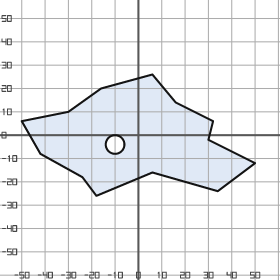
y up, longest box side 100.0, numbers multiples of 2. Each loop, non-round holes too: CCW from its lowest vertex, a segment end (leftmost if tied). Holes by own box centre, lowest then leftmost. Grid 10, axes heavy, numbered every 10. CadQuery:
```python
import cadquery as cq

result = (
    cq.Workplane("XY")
    .moveTo(-18.0, -26.0)
    .lineTo(6.0, -16.0)
    .lineTo(34.0, -24.0)
    .lineTo(50.0, -12.0)
    .lineTo(30.0, -2.0)
    .lineTo(32.0, 6.0)
    .lineTo(16.0, 14.0)
    .lineTo(6.0, 26.0)
    .lineTo(-16.0, 20.0)
    .lineTo(-30.0, 10.0)
    .lineTo(-50.0, 6.0)
    .lineTo(-42.0, -8.0)
    .lineTo(-24.0, -18.0)
    .close()
    .moveTo(-10.0, -4.0)
    .circle(4.0)
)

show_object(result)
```